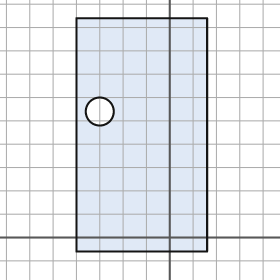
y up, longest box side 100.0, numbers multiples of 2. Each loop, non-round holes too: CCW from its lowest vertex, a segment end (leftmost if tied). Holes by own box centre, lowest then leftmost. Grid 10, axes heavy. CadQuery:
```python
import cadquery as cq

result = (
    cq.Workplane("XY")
    .moveTo(-40.0, -6.0)
    .lineTo(16.0, -6.0)
    .lineTo(16.0, 94.0)
    .lineTo(-40.0, 94.0)
    .close()
    .moveTo(-30.0, 54.0)
    .circle(6.0)
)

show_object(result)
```